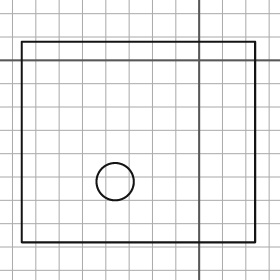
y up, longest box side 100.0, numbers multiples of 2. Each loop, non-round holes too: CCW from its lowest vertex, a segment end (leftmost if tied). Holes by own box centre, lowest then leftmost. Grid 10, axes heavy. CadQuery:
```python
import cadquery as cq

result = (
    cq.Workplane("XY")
    .moveTo(-76.0, -78.0)
    .lineTo(24.0, -78.0)
    .lineTo(24.0, 8.0)
    .lineTo(-76.0, 8.0)
    .close()
    .moveTo(-36.0, -52.0)
    .circle(8.0)
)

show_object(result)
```